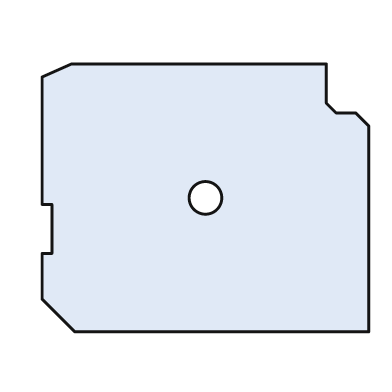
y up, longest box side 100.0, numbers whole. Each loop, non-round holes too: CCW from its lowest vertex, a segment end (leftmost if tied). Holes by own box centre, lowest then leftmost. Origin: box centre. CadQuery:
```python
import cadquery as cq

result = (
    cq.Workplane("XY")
    .moveTo(-40.0, -41.0)
    .lineTo(50.0, -41.0)
    .lineTo(50.0, 22.0)
    .lineTo(46.0, 26.0)
    .lineTo(40.0, 26.0)
    .lineTo(37.0, 29.0)
    .lineTo(37.0, 41.0)
    .lineTo(-41.0, 41.0)
    .lineTo(-50.0, 37.0)
    .lineTo(-50.0, -2.0)
    .lineTo(-47.0, -2.0)
    .lineTo(-47.0, -17.0)
    .lineTo(-50.0, -17.0)
    .lineTo(-50.0, -31.0)
    .close()
    .moveTo(0.0, 0.0)
    .circle(5.0)
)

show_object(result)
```